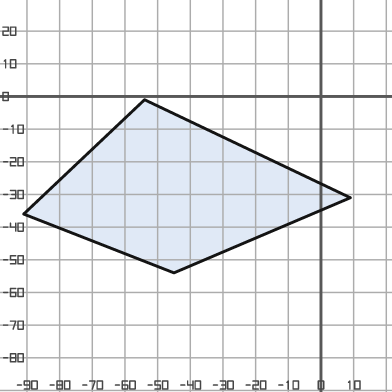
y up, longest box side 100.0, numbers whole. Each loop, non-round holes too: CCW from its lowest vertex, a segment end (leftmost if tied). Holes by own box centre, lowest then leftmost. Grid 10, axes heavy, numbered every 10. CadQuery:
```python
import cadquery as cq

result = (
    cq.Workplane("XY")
    .moveTo(-45.0, -54.0)
    .lineTo(9.0, -31.0)
    .lineTo(-54.0, -1.0)
    .lineTo(-91.0, -36.0)
    .close()
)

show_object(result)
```